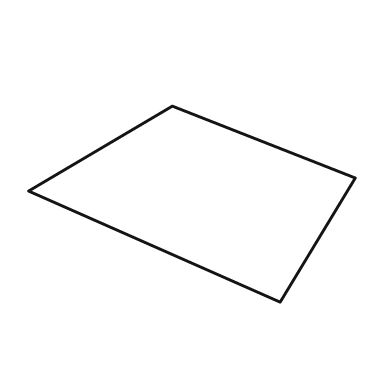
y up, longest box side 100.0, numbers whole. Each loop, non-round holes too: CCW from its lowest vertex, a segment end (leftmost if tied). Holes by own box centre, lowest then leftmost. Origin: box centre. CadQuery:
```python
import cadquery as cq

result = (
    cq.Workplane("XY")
    .moveTo(27.0, -30.0)
    .lineTo(50.0, 8.0)
    .lineTo(-6.0, 30.0)
    .lineTo(-50.0, 4.0)
    .close()
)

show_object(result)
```